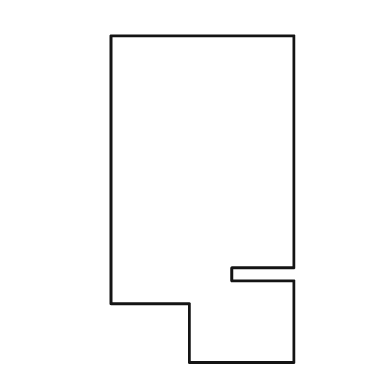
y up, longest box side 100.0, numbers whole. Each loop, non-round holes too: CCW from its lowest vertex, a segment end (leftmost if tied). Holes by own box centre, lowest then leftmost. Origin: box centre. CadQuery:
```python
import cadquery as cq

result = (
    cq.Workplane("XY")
    .moveTo(-4.0, -50.0)
    .lineTo(28.0, -50.0)
    .lineTo(28.0, -25.0)
    .lineTo(9.0, -25.0)
    .lineTo(9.0, -21.0)
    .lineTo(28.0, -21.0)
    .lineTo(28.0, 50.0)
    .lineTo(-28.0, 50.0)
    .lineTo(-28.0, -32.0)
    .lineTo(-4.0, -32.0)
    .close()
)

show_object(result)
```